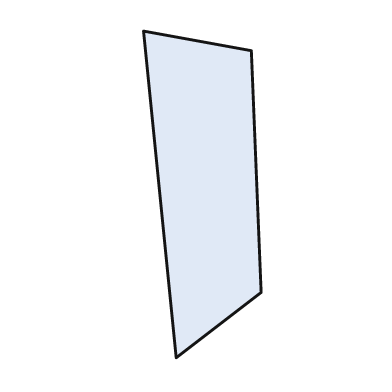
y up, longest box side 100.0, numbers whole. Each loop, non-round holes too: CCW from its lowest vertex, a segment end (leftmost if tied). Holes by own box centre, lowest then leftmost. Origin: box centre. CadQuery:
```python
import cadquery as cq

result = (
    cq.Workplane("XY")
    .moveTo(-8.0, -50.0)
    .lineTo(18.0, -30.0)
    .lineTo(15.0, 44.0)
    .lineTo(-18.0, 50.0)
    .close()
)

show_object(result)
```